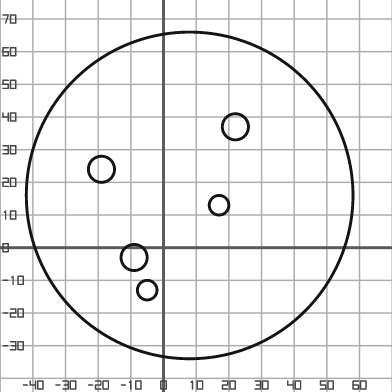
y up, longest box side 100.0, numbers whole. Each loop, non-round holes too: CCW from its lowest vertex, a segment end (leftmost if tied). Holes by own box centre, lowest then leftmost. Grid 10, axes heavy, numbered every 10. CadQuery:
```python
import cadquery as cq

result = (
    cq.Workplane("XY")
    .moveTo(8.0, 16.0)
    .circle(50.0)
    .moveTo(-5.0, -13.0)
    .circle(3.0)
    .moveTo(-9.0, -3.0)
    .circle(4.0)
    .moveTo(17.0, 13.0)
    .circle(3.0)
    .moveTo(-19.0, 24.0)
    .circle(4.0)
    .moveTo(22.0, 37.0)
    .circle(4.0)
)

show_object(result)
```